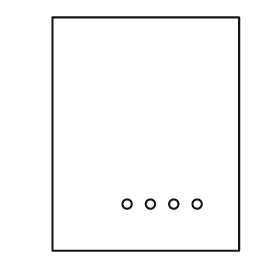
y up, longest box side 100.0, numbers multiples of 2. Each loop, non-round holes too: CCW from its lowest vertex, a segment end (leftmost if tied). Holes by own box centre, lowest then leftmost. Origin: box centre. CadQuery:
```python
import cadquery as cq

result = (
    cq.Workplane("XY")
    .moveTo(-40.0, -50.0)
    .lineTo(40.0, -50.0)
    .lineTo(40.0, 50.0)
    .lineTo(-40.0, 50.0)
    .close()
    .moveTo(-8.0, -30.0)
    .circle(2.0)
    .moveTo(2.0, -30.0)
    .circle(2.0)
    .moveTo(12.0, -30.0)
    .circle(2.0)
    .moveTo(22.0, -30.0)
    .circle(2.0)
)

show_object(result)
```